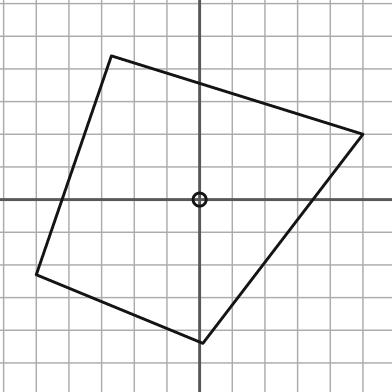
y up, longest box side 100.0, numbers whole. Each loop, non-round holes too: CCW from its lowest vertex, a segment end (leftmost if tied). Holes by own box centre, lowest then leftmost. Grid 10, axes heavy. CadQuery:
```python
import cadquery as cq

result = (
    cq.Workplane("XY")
    .moveTo(1.0, -44.0)
    .lineTo(50.0, 20.0)
    .lineTo(-27.0, 44.0)
    .lineTo(-50.0, -23.0)
    .close()
    .moveTo(0.0, 0.0)
    .circle(2.0)
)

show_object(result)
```